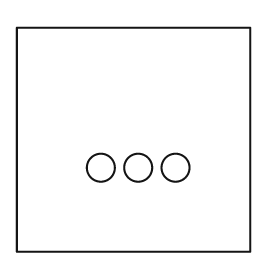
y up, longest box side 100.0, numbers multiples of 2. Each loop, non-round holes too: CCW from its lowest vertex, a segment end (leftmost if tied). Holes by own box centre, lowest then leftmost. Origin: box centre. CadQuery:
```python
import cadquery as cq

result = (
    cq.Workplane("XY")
    .moveTo(-50.0, -48.0)
    .lineTo(50.0, -48.0)
    .lineTo(50.0, 48.0)
    .lineTo(-50.0, 48.0)
    .close()
    .moveTo(-14.0, -12.0)
    .circle(6.0)
    .moveTo(2.0, -12.0)
    .circle(6.0)
    .moveTo(18.0, -12.0)
    .circle(6.0)
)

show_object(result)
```